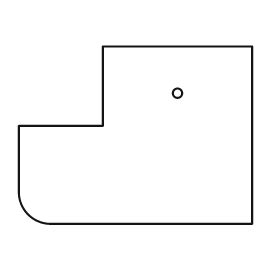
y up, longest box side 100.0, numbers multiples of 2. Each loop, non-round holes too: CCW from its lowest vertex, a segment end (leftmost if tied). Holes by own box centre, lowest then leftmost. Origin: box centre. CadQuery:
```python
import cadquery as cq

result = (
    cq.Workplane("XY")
    .moveTo(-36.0, -38.0)
    .lineTo(50.0, -38.0)
    .lineTo(50.0, 38.0)
    .lineTo(-14.0, 38.0)
    .lineTo(-14.0, 4.0)
    .lineTo(-50.0, 4.0)
    .lineTo(-50.0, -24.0)
    .threePointArc((-46.0, -34.0), (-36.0, -38.0))
    .close()
    .moveTo(18.0, 18.0)
    .circle(2.0)
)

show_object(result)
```